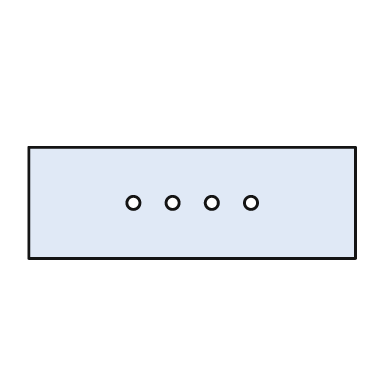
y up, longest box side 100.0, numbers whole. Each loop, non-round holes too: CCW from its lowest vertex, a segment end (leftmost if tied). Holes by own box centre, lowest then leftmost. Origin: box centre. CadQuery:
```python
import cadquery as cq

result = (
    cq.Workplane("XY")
    .moveTo(-50.0, -17.0)
    .lineTo(50.0, -17.0)
    .lineTo(50.0, 17.0)
    .lineTo(-50.0, 17.0)
    .close()
    .moveTo(-18.0, 0.0)
    .circle(2.0)
    .moveTo(-6.0, 0.0)
    .circle(2.0)
    .moveTo(6.0, 0.0)
    .circle(2.0)
    .moveTo(18.0, 0.0)
    .circle(2.0)
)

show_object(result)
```